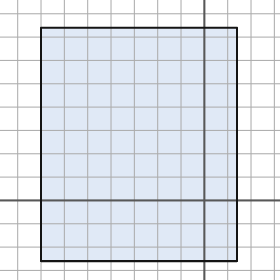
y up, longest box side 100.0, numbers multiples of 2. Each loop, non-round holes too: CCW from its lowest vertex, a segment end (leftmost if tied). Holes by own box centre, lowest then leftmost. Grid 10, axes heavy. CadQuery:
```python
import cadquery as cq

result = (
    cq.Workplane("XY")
    .moveTo(-70.0, -26.0)
    .lineTo(14.0, -26.0)
    .lineTo(14.0, 74.0)
    .lineTo(-70.0, 74.0)
    .close()
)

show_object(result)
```